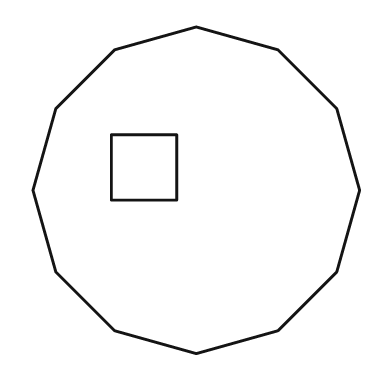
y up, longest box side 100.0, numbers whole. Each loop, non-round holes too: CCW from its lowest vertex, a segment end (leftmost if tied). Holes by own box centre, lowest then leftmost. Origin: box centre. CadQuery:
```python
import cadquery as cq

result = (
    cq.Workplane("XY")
    .moveTo(0.0, -50.0)
    .lineTo(25.0, -43.0)
    .lineTo(43.0, -25.0)
    .lineTo(50.0, 0.0)
    .lineTo(43.0, 25.0)
    .lineTo(25.0, 43.0)
    .lineTo(0.0, 50.0)
    .lineTo(-25.0, 43.0)
    .lineTo(-43.0, 25.0)
    .lineTo(-50.0, 0.0)
    .lineTo(-43.0, -25.0)
    .lineTo(-25.0, -43.0)
    .close()
    .moveTo(-26.0, -3.0)
    .lineTo(-6.0, -3.0)
    .lineTo(-6.0, 17.0)
    .lineTo(-26.0, 17.0)
    .close()
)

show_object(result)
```